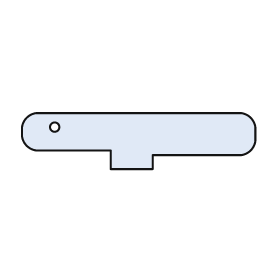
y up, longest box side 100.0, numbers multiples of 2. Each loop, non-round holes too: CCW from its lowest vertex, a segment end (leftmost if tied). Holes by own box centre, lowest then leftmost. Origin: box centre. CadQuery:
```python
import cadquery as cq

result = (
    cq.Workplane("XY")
    .moveTo(-12.0, -12.0)
    .lineTo(6.0, -12.0)
    .lineTo(6.0, -6.0)
    .lineTo(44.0, -6.0)
    .threePointArc((48.0, -4.0), (50.0, 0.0))
    .lineTo(50.0, 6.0)
    .threePointArc((48.0, 10.0), (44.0, 12.0))
    .lineTo(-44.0, 12.0)
    .threePointArc((-48.0, 10.0), (-50.0, 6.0))
    .lineTo(-50.0, 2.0)
    .threePointArc((-48.0, -2.0), (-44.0, -4.0))
    .lineTo(-12.0, -4.0)
    .close()
    .moveTo(-36.0, 6.0)
    .circle(2.0)
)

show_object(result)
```